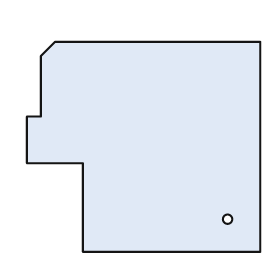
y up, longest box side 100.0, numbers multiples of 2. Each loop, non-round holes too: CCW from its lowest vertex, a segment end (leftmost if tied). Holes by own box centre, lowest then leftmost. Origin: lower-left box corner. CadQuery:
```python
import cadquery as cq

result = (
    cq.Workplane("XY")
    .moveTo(24.0, 0.0)
    .lineTo(100.0, 0.0)
    .lineTo(100.0, 90.0)
    .lineTo(12.0, 90.0)
    .lineTo(6.0, 84.0)
    .lineTo(6.0, 58.0)
    .lineTo(0.0, 58.0)
    .lineTo(0.0, 38.0)
    .lineTo(24.0, 38.0)
    .close()
    .moveTo(86.0, 14.0)
    .circle(2.0)
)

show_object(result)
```